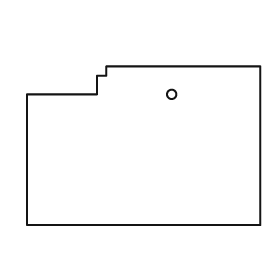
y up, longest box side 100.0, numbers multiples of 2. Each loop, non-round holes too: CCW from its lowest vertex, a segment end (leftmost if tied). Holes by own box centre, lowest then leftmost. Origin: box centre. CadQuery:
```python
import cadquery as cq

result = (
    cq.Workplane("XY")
    .moveTo(-50.0, -34.0)
    .lineTo(50.0, -34.0)
    .lineTo(50.0, 34.0)
    .lineTo(-16.0, 34.0)
    .lineTo(-16.0, 30.0)
    .lineTo(-20.0, 30.0)
    .lineTo(-20.0, 22.0)
    .lineTo(-50.0, 22.0)
    .close()
    .moveTo(12.0, 22.0)
    .circle(2.0)
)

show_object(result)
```